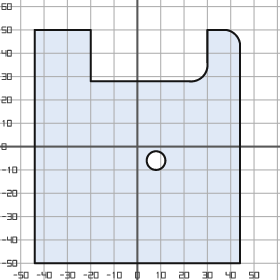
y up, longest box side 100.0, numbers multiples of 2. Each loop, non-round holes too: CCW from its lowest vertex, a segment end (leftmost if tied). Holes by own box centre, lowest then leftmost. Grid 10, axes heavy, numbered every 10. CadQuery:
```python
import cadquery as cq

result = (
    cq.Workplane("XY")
    .moveTo(-44.0, -50.0)
    .lineTo(44.0, -50.0)
    .lineTo(44.0, 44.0)
    .threePointArc((42.0, 48.0), (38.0, 50.0))
    .lineTo(30.0, 50.0)
    .lineTo(30.0, 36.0)
    .threePointArc((28.0, 30.0), (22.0, 28.0))
    .lineTo(-20.0, 28.0)
    .lineTo(-20.0, 50.0)
    .lineTo(-44.0, 50.0)
    .close()
    .moveTo(8.0, -6.0)
    .circle(4.0)
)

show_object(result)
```